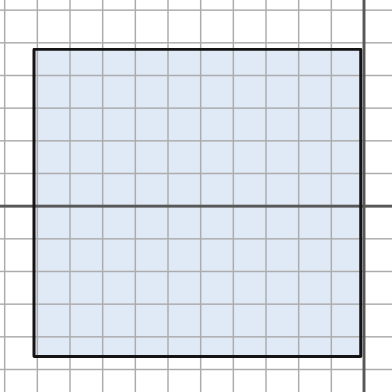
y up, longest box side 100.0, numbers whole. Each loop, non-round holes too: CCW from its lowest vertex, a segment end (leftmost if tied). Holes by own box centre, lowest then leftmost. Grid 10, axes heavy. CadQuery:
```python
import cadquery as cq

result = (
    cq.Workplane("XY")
    .moveTo(-101.0, -46.0)
    .lineTo(-1.0, -46.0)
    .lineTo(-1.0, 48.0)
    .lineTo(-101.0, 48.0)
    .close()
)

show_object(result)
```